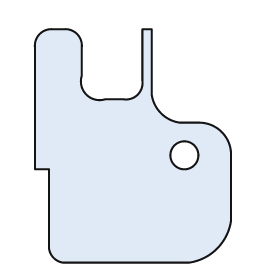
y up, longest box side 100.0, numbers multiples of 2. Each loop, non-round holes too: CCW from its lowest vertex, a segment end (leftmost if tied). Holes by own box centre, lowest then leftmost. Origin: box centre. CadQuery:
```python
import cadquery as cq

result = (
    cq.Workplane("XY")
    .moveTo(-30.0, -50.0)
    .lineTo(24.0, -50.0)
    .threePointArc((36.0, -44.0), (42.0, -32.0))
    .lineTo(42.0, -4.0)
    .threePointArc((38.0, 6.0), (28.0, 10.0))
    .lineTo(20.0, 10.0)
    .threePointArc((12.0, 14.0), (8.0, 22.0))
    .lineTo(8.0, 50.0)
    .lineTo(4.0, 50.0)
    .lineTo(4.0, 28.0)
    .threePointArc((2.0, 22.0), (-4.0, 20.0))
    .lineTo(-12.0, 20.0)
    .threePointArc((-20.0, 22.0), (-22.0, 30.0))
    .lineTo(-22.0, 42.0)
    .threePointArc((-24.0, 48.0), (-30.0, 50.0))
    .lineTo(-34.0, 50.0)
    .threePointArc((-40.0, 48.0), (-42.0, 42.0))
    .lineTo(-42.0, -10.0)
    .lineTo(-36.0, -10.0)
    .lineTo(-36.0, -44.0)
    .threePointArc((-34.0, -48.0), (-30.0, -50.0))
    .close()
    .moveTo(22.0, -4.0)
    .circle(6.0)
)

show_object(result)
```